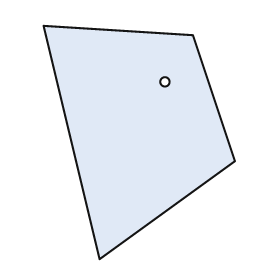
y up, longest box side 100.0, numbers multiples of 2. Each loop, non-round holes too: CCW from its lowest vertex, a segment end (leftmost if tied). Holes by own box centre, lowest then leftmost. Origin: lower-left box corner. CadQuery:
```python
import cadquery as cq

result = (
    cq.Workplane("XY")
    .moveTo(24.0, 0.0)
    .lineTo(82.0, 42.0)
    .lineTo(64.0, 96.0)
    .lineTo(0.0, 100.0)
    .close()
    .moveTo(52.0, 76.0)
    .circle(2.0)
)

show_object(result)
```